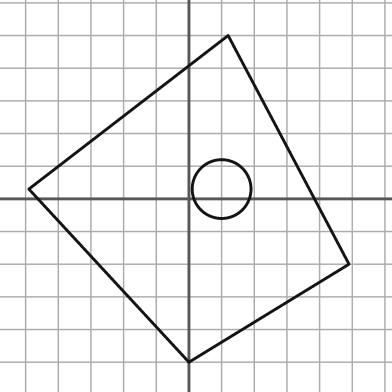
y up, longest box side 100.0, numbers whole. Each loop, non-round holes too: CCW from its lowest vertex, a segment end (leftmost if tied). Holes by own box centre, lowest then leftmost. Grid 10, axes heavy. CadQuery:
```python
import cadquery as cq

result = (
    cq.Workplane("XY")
    .moveTo(0.0, -50.0)
    .lineTo(49.0, -20.0)
    .lineTo(12.0, 50.0)
    .lineTo(-49.0, 3.0)
    .close()
    .moveTo(10.0, 3.0)
    .circle(9.0)
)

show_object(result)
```